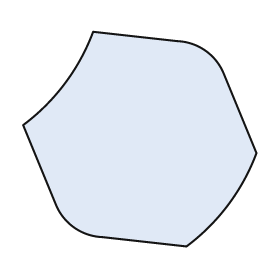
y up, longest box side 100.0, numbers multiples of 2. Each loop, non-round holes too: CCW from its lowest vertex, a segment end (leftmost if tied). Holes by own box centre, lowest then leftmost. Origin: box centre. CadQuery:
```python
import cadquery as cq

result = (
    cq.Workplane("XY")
    .moveTo(20.0, -46.0)
    .threePointArc((38.0, -28.0), (50.0, -6.0))
    .lineTo(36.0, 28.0)
    .threePointArc((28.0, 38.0), (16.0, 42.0))
    .lineTo(-20.0, 46.0)
    .threePointArc((-32.0, 24.0), (-50.0, 6.0))
    .lineTo(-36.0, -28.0)
    .threePointArc((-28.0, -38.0), (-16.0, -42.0))
    .close()
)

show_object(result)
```